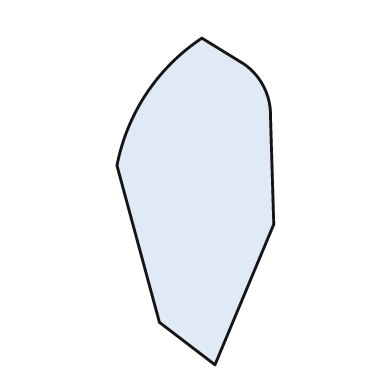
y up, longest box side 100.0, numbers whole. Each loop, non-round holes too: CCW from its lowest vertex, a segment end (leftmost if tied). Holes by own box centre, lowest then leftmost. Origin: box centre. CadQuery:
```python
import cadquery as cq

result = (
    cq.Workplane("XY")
    .moveTo(6.0, -50.0)
    .lineTo(24.0, -7.0)
    .lineTo(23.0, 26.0)
    .threePointArc((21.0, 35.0), (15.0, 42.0))
    .lineTo(2.0, 50.0)
    .threePointArc((-15.0, 33.0), (-24.0, 11.0))
    .lineTo(-11.0, -37.0)
    .close()
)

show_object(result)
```